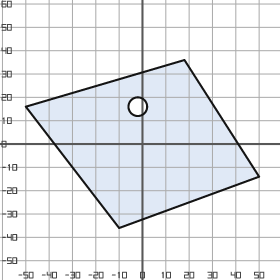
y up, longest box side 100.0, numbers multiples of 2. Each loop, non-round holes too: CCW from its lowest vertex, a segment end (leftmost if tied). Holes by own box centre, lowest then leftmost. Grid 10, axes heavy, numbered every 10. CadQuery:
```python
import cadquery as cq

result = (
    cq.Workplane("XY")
    .moveTo(-10.0, -36.0)
    .lineTo(50.0, -14.0)
    .lineTo(18.0, 36.0)
    .lineTo(-50.0, 16.0)
    .close()
    .moveTo(-2.0, 16.0)
    .circle(4.0)
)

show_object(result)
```